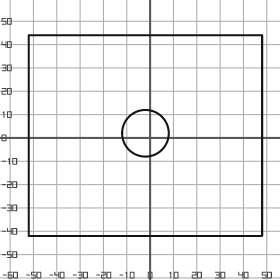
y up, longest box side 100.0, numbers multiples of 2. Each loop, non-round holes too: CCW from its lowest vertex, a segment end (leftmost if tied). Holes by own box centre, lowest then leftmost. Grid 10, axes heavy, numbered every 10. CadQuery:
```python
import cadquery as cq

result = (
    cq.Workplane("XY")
    .moveTo(-52.0, -42.0)
    .lineTo(48.0, -42.0)
    .lineTo(48.0, 44.0)
    .lineTo(-52.0, 44.0)
    .close()
    .moveTo(-2.0, 2.0)
    .circle(10.0)
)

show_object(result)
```